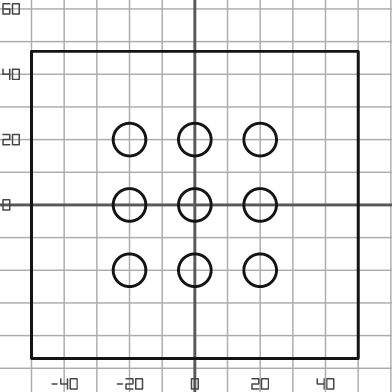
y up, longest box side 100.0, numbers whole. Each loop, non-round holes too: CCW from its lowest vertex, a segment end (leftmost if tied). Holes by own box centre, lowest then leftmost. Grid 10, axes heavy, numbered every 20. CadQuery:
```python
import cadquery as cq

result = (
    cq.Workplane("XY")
    .moveTo(-50.0, -47.0)
    .lineTo(50.0, -47.0)
    .lineTo(50.0, 47.0)
    .lineTo(-50.0, 47.0)
    .close()
    .moveTo(-20.0, -20.0)
    .circle(5.0)
    .moveTo(0.0, -20.0)
    .circle(5.0)
    .moveTo(20.0, -20.0)
    .circle(5.0)
    .moveTo(-20.0, 0.0)
    .circle(5.0)
    .moveTo(0.0, 0.0)
    .circle(5.0)
    .moveTo(20.0, 0.0)
    .circle(5.0)
    .moveTo(-20.0, 20.0)
    .circle(5.0)
    .moveTo(0.0, 20.0)
    .circle(5.0)
    .moveTo(20.0, 20.0)
    .circle(5.0)
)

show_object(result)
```